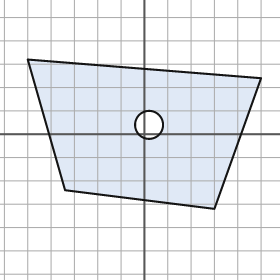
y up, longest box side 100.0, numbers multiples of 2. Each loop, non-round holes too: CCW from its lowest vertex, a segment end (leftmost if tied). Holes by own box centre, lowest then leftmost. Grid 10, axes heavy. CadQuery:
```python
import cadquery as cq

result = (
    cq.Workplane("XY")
    .moveTo(30.0, -32.0)
    .lineTo(50.0, 24.0)
    .lineTo(-50.0, 32.0)
    .lineTo(-34.0, -24.0)
    .close()
    .moveTo(2.0, 4.0)
    .circle(6.0)
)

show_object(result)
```